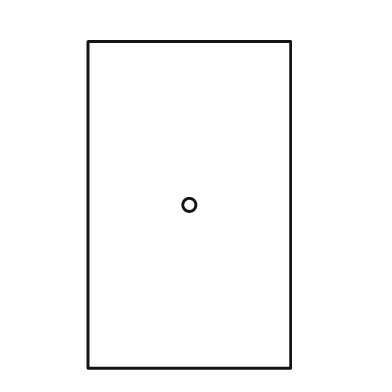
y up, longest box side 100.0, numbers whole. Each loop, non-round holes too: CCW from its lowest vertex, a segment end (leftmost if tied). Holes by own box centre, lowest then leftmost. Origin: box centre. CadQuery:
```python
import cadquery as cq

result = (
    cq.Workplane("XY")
    .moveTo(-31.0, -50.0)
    .lineTo(31.0, -50.0)
    .lineTo(31.0, 50.0)
    .lineTo(-31.0, 50.0)
    .close()
    .moveTo(0.0, 0.0)
    .circle(2.0)
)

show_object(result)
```